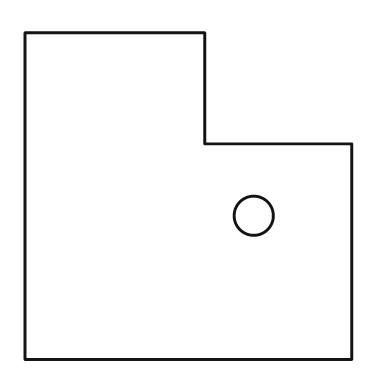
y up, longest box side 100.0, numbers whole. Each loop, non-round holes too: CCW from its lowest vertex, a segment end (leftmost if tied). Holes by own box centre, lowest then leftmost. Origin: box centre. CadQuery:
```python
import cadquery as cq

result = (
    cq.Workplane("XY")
    .moveTo(-50.0, -50.0)
    .lineTo(50.0, -50.0)
    .lineTo(50.0, 16.0)
    .lineTo(5.0, 16.0)
    .lineTo(5.0, 50.0)
    .lineTo(-50.0, 50.0)
    .close()
    .moveTo(20.0, -6.0)
    .circle(6.0)
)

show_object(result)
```